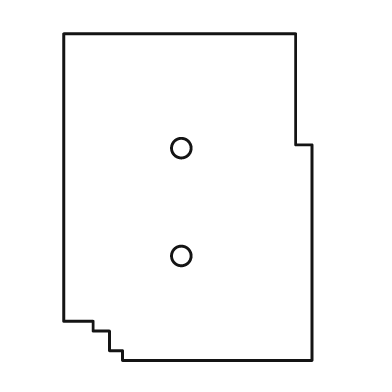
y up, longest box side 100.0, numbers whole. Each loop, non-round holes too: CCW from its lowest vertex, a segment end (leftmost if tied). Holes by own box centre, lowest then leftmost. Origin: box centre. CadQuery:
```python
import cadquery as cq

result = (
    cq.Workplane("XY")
    .moveTo(-20.0, -50.0)
    .lineTo(38.0, -50.0)
    .lineTo(38.0, 16.0)
    .lineTo(33.0, 16.0)
    .lineTo(33.0, 50.0)
    .lineTo(-38.0, 50.0)
    .lineTo(-38.0, -38.0)
    .lineTo(-29.0, -38.0)
    .lineTo(-29.0, -41.0)
    .lineTo(-24.0, -41.0)
    .lineTo(-24.0, -47.0)
    .lineTo(-20.0, -47.0)
    .close()
    .moveTo(-2.0, -18.0)
    .circle(3.0)
    .moveTo(-2.0, 15.0)
    .circle(3.0)
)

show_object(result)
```